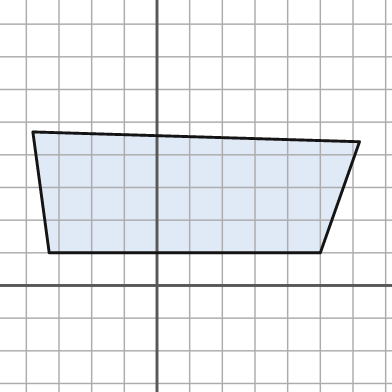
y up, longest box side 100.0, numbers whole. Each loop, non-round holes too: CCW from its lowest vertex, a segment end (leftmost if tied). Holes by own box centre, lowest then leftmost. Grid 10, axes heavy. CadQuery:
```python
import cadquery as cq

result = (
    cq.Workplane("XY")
    .moveTo(-33.0, 10.0)
    .lineTo(50.0, 10.0)
    .lineTo(62.0, 44.0)
    .lineTo(-38.0, 47.0)
    .close()
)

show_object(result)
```